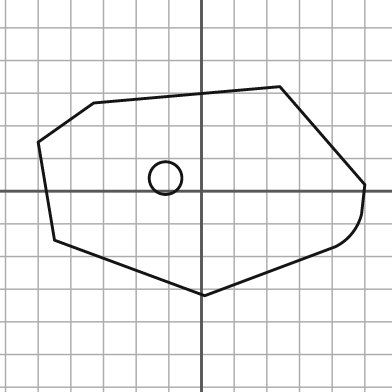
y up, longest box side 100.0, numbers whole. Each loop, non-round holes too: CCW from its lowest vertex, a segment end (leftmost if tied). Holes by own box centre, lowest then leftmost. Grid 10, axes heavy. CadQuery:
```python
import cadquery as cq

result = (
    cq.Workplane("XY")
    .moveTo(1.0, -32.0)
    .lineTo(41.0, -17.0)
    .threePointArc((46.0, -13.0), (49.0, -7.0))
    .lineTo(50.0, 2.0)
    .lineTo(24.0, 32.0)
    .lineTo(-33.0, 27.0)
    .lineTo(-50.0, 15.0)
    .lineTo(-45.0, -15.0)
    .close()
    .moveTo(-11.0, 4.0)
    .circle(5.0)
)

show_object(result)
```